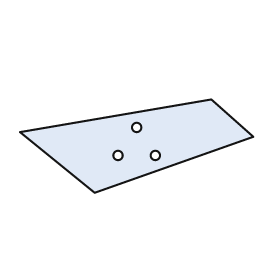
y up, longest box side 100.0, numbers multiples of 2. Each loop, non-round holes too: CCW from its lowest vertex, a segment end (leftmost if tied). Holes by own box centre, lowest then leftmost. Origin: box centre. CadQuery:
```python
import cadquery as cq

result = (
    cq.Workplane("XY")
    .moveTo(-18.0, -20.0)
    .lineTo(50.0, 4.0)
    .lineTo(32.0, 20.0)
    .lineTo(-50.0, 6.0)
    .close()
    .moveTo(-8.0, -4.0)
    .circle(2.0)
    .moveTo(8.0, -4.0)
    .circle(2.0)
    .moveTo(0.0, 8.0)
    .circle(2.0)
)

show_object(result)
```